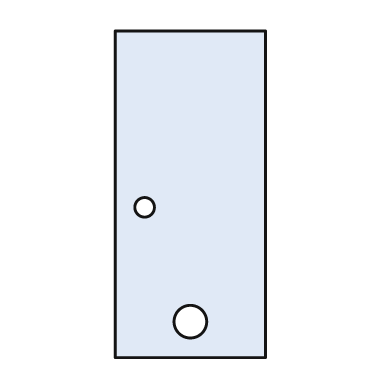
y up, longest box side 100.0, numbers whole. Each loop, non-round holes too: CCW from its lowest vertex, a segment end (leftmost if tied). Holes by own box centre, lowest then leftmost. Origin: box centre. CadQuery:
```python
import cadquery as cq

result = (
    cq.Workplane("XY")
    .moveTo(-23.0, -50.0)
    .lineTo(23.0, -50.0)
    .lineTo(23.0, 50.0)
    .lineTo(-23.0, 50.0)
    .close()
    .moveTo(0.0, -39.0)
    .circle(5.0)
    .moveTo(-14.0, -4.0)
    .circle(3.0)
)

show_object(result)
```